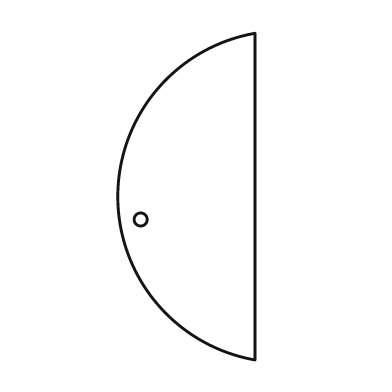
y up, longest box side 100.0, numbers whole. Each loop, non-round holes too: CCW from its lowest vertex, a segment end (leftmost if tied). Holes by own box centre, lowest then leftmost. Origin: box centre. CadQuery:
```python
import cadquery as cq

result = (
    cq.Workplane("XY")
    .moveTo(21.0, -50.0)
    .lineTo(21.0, 50.0)
    .threePointArc((-21.0, 0.0), (21.0, -50.0))
    .close()
    .moveTo(-14.0, -7.0)
    .circle(2.0)
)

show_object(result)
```